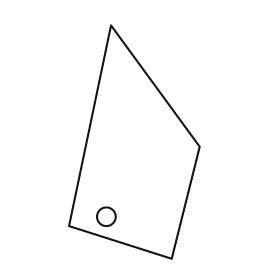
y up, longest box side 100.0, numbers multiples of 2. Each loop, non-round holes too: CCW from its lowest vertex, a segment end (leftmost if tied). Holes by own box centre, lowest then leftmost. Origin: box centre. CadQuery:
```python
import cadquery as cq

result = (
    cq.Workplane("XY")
    .moveTo(16.0, -50.0)
    .lineTo(28.0, -2.0)
    .lineTo(-10.0, 50.0)
    .lineTo(-28.0, -36.0)
    .close()
    .moveTo(-12.0, -32.0)
    .circle(4.0)
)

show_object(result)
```